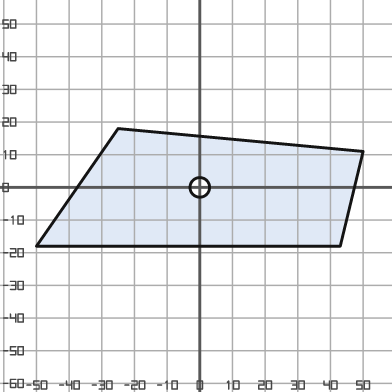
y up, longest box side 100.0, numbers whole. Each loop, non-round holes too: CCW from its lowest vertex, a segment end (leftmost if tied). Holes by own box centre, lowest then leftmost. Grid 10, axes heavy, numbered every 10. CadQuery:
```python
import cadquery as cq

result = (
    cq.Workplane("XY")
    .moveTo(-50.0, -18.0)
    .lineTo(43.0, -18.0)
    .lineTo(50.0, 11.0)
    .lineTo(-25.0, 18.0)
    .close()
    .moveTo(0.0, 0.0)
    .circle(3.0)
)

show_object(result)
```